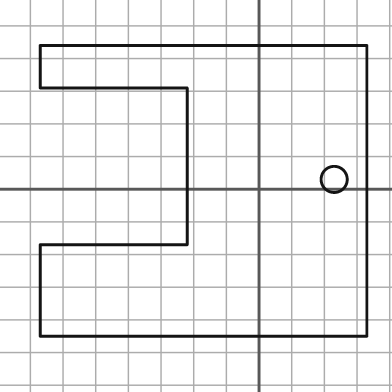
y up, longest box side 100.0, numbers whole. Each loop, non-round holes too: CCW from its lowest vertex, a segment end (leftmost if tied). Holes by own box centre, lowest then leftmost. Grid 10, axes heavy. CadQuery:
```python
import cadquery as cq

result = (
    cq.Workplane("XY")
    .moveTo(-67.0, -45.0)
    .lineTo(33.0, -45.0)
    .lineTo(33.0, 44.0)
    .lineTo(-67.0, 44.0)
    .lineTo(-67.0, 31.0)
    .lineTo(-22.0, 31.0)
    .lineTo(-22.0, -17.0)
    .lineTo(-67.0, -17.0)
    .close()
    .moveTo(23.0, 3.0)
    .circle(4.0)
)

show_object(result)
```